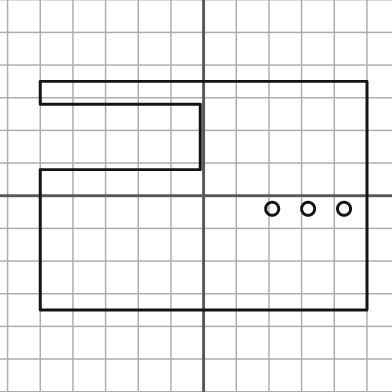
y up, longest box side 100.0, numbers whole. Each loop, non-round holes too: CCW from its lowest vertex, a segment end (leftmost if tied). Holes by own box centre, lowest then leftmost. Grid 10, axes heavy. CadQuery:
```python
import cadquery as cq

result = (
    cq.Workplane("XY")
    .moveTo(-50.0, -35.0)
    .lineTo(50.0, -35.0)
    .lineTo(50.0, 35.0)
    .lineTo(-50.0, 35.0)
    .lineTo(-50.0, 28.0)
    .lineTo(-1.0, 28.0)
    .lineTo(-1.0, 8.0)
    .lineTo(-50.0, 8.0)
    .close()
    .moveTo(21.0, -4.0)
    .circle(2.0)
    .moveTo(32.0, -4.0)
    .circle(2.0)
    .moveTo(43.0, -4.0)
    .circle(2.0)
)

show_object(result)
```